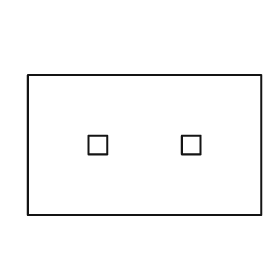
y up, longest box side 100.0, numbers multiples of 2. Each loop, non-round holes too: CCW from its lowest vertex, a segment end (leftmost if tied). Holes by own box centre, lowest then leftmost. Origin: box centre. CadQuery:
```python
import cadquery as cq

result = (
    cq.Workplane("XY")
    .moveTo(-50.0, -30.0)
    .lineTo(50.0, -30.0)
    .lineTo(50.0, 30.0)
    .lineTo(-50.0, 30.0)
    .close()
    .moveTo(-24.0, -4.0)
    .lineTo(-16.0, -4.0)
    .lineTo(-16.0, 4.0)
    .lineTo(-24.0, 4.0)
    .close()
    .moveTo(16.0, -4.0)
    .lineTo(24.0, -4.0)
    .lineTo(24.0, 4.0)
    .lineTo(16.0, 4.0)
    .close()
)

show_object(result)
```